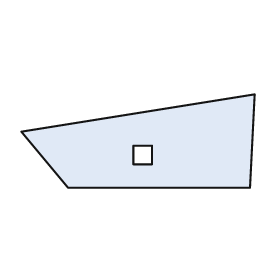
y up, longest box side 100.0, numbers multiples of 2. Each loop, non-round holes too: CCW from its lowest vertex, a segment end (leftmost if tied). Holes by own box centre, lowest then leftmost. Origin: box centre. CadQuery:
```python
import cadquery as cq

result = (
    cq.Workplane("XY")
    .moveTo(-30.0, -20.0)
    .lineTo(48.0, -20.0)
    .lineTo(50.0, 20.0)
    .lineTo(-50.0, 4.0)
    .close()
    .moveTo(-2.0, -10.0)
    .lineTo(6.0, -10.0)
    .lineTo(6.0, -2.0)
    .lineTo(-2.0, -2.0)
    .close()
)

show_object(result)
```